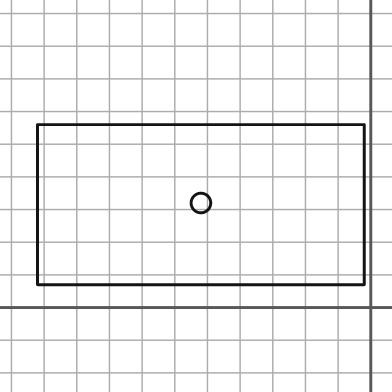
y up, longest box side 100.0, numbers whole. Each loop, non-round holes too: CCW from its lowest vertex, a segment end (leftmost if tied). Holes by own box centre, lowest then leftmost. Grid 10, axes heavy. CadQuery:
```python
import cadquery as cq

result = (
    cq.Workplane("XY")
    .moveTo(-102.0, 7.0)
    .lineTo(-2.0, 7.0)
    .lineTo(-2.0, 56.0)
    .lineTo(-102.0, 56.0)
    .close()
    .moveTo(-52.0, 32.0)
    .circle(3.0)
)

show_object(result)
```